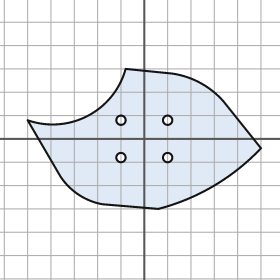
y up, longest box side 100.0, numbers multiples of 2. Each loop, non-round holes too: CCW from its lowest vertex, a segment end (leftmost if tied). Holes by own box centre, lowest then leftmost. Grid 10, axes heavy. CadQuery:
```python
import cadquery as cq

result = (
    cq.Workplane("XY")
    .moveTo(6.0, -30.0)
    .threePointArc((30.0, -20.0), (50.0, -4.0))
    .lineTo(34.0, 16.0)
    .threePointArc((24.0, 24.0), (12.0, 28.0))
    .lineTo(-8.0, 30.0)
    .threePointArc((-24.0, 10.0), (-50.0, 8.0))
    .lineTo(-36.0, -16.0)
    .threePointArc((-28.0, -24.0), (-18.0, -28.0))
    .close()
    .moveTo(-10.0, -8.0)
    .circle(2.0)
    .moveTo(10.0, -8.0)
    .circle(2.0)
    .moveTo(-10.0, 8.0)
    .circle(2.0)
    .moveTo(10.0, 8.0)
    .circle(2.0)
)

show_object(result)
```